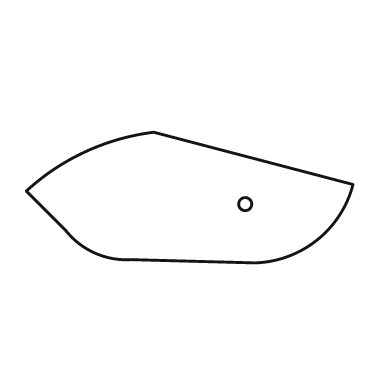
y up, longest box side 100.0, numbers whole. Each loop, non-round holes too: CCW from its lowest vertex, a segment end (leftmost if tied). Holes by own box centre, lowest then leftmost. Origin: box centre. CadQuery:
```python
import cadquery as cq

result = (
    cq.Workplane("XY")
    .moveTo(20.0, -20.0)
    .threePointArc((39.0, -13.0), (50.0, 4.0))
    .lineTo(-11.0, 20.0)
    .threePointArc((-32.0, 14.0), (-50.0, 2.0))
    .lineTo(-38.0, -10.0)
    .threePointArc((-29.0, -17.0), (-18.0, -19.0))
    .close()
    .moveTo(17.0, -2.0)
    .circle(2.0)
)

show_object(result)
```